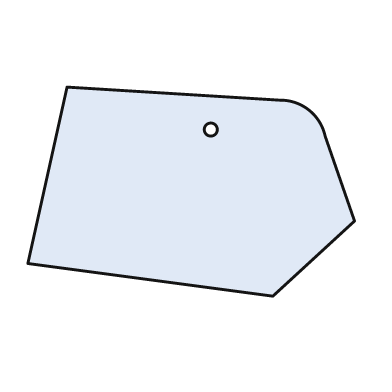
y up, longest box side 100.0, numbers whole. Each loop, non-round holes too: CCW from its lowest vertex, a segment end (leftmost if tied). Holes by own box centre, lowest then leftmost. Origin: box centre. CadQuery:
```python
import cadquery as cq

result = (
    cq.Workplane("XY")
    .moveTo(25.0, -32.0)
    .lineTo(50.0, -9.0)
    .lineTo(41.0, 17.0)
    .threePointArc((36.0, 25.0), (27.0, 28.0))
    .lineTo(-38.0, 32.0)
    .lineTo(-50.0, -22.0)
    .close()
    .moveTo(6.0, 19.0)
    .circle(2.0)
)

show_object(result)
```